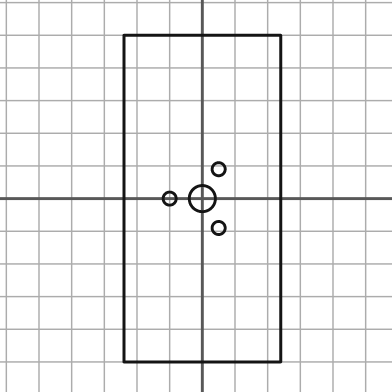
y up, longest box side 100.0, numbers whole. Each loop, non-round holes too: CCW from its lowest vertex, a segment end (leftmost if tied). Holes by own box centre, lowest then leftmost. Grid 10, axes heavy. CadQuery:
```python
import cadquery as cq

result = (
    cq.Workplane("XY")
    .moveTo(-24.0, -50.0)
    .lineTo(24.0, -50.0)
    .lineTo(24.0, 50.0)
    .lineTo(-24.0, 50.0)
    .close()
    .moveTo(5.0, -9.0)
    .circle(2.0)
    .moveTo(-10.0, 0.0)
    .circle(2.0)
    .moveTo(0.0, 0.0)
    .circle(4.0)
    .moveTo(5.0, 9.0)
    .circle(2.0)
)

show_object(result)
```